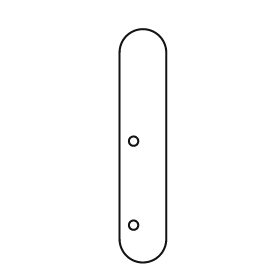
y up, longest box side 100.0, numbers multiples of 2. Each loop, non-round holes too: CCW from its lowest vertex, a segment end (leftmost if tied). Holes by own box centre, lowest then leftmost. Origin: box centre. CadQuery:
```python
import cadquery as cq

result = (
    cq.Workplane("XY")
    .moveTo(-10.0, -40.0)
    .threePointArc((0.0, -50.0), (10.0, -40.0))
    .lineTo(10.0, 40.0)
    .threePointArc((0.0, 50.0), (-10.0, 40.0))
    .close()
    .moveTo(-4.0, -34.0)
    .circle(2.0)
    .moveTo(-4.0, 2.0)
    .circle(2.0)
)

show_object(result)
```